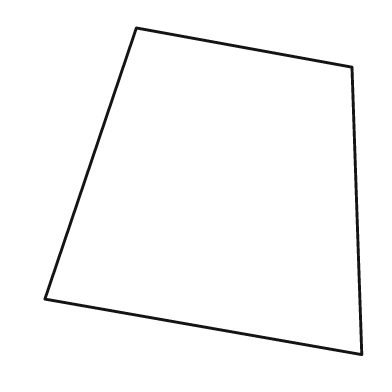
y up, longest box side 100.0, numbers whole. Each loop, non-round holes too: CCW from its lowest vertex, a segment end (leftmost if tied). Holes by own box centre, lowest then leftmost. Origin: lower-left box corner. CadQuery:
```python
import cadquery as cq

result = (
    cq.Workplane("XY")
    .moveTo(97.0, 0.0)
    .lineTo(94.0, 88.0)
    .lineTo(28.0, 100.0)
    .lineTo(0.0, 17.0)
    .close()
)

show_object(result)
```